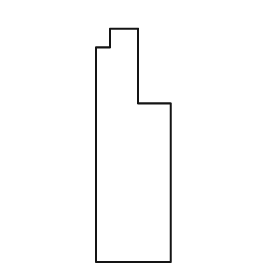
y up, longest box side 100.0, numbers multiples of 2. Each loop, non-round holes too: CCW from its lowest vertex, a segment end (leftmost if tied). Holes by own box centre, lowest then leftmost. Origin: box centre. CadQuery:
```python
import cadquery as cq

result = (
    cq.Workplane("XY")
    .moveTo(-16.0, -50.0)
    .lineTo(16.0, -50.0)
    .lineTo(16.0, 18.0)
    .lineTo(2.0, 18.0)
    .lineTo(2.0, 50.0)
    .lineTo(-10.0, 50.0)
    .lineTo(-10.0, 42.0)
    .lineTo(-16.0, 42.0)
    .close()
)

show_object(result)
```